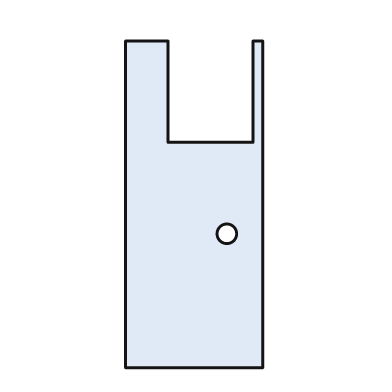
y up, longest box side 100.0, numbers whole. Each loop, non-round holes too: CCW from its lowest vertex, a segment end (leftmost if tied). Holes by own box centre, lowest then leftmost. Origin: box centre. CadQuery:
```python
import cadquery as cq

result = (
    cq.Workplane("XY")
    .moveTo(-21.0, -50.0)
    .lineTo(21.0, -50.0)
    .lineTo(21.0, 50.0)
    .lineTo(18.0, 50.0)
    .lineTo(18.0, 19.0)
    .lineTo(-8.0, 19.0)
    .lineTo(-8.0, 50.0)
    .lineTo(-21.0, 50.0)
    .close()
    .moveTo(10.0, -9.0)
    .circle(3.0)
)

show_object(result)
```